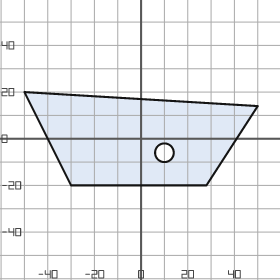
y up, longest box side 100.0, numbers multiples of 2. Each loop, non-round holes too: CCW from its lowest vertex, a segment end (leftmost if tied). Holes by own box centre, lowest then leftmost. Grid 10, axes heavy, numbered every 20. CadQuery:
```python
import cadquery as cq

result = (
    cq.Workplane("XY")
    .moveTo(-30.0, -20.0)
    .lineTo(28.0, -20.0)
    .lineTo(50.0, 14.0)
    .lineTo(-50.0, 20.0)
    .close()
    .moveTo(10.0, -6.0)
    .circle(4.0)
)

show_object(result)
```